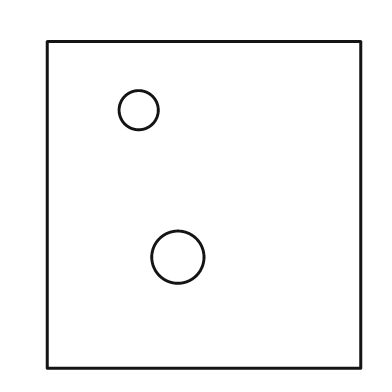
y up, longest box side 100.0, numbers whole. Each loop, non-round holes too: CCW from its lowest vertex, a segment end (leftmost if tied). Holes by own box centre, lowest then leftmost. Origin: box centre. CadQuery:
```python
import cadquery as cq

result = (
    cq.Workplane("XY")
    .moveTo(-48.0, -50.0)
    .lineTo(48.0, -50.0)
    .lineTo(48.0, 50.0)
    .lineTo(-48.0, 50.0)
    .close()
    .moveTo(-8.0, -16.0)
    .circle(8.0)
    .moveTo(-20.0, 29.0)
    .circle(6.0)
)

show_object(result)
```